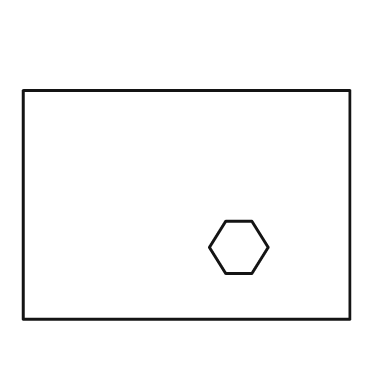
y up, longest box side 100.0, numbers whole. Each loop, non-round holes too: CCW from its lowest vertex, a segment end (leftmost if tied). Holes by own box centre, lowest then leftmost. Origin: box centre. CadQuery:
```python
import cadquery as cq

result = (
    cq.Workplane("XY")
    .moveTo(-50.0, -35.0)
    .lineTo(50.0, -35.0)
    .lineTo(50.0, 35.0)
    .lineTo(-50.0, 35.0)
    .close()
    .moveTo(12.0, -21.0)
    .lineTo(20.0, -21.0)
    .lineTo(25.0, -13.0)
    .lineTo(20.0, -5.0)
    .lineTo(12.0, -5.0)
    .lineTo(7.0, -13.0)
    .close()
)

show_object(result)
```